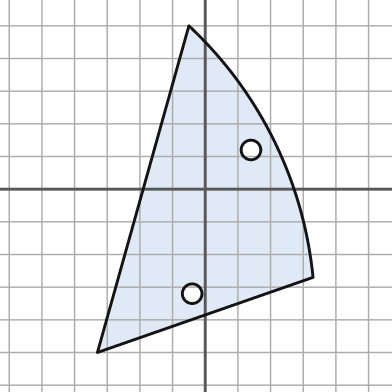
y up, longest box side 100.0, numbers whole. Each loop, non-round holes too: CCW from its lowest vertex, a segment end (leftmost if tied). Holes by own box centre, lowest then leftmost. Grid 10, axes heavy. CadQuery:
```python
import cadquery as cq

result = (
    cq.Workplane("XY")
    .moveTo(-33.0, -50.0)
    .lineTo(33.0, -27.0)
    .threePointArc((21.0, 15.0), (-5.0, 50.0))
    .close()
    .moveTo(-4.0, -32.0)
    .circle(3.0)
    .moveTo(14.0, 12.0)
    .circle(3.0)
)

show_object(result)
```